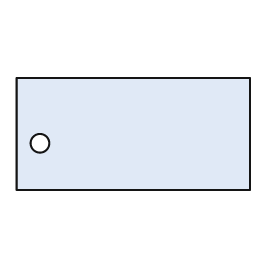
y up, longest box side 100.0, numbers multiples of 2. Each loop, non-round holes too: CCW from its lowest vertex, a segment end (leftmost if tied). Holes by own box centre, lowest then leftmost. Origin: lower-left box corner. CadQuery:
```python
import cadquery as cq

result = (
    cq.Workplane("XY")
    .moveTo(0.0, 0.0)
    .lineTo(100.0, 0.0)
    .lineTo(100.0, 48.0)
    .lineTo(0.0, 48.0)
    .close()
    .moveTo(10.0, 20.0)
    .circle(4.0)
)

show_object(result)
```